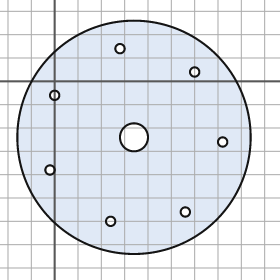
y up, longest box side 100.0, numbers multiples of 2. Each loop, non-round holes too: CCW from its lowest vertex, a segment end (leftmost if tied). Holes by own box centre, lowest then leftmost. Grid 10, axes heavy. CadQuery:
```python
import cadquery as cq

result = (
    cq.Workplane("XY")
    .moveTo(34.0, -24.0)
    .circle(50.0)
    .moveTo(24.0, -60.0)
    .circle(2.0)
    .moveTo(56.0, -56.0)
    .circle(2.0)
    .moveTo(-2.0, -38.0)
    .circle(2.0)
    .moveTo(72.0, -26.0)
    .circle(2.0)
    .moveTo(34.0, -24.0)
    .circle(6.0)
    .moveTo(0.0, -6.0)
    .circle(2.0)
    .moveTo(60.0, 4.0)
    .circle(2.0)
    .moveTo(28.0, 14.0)
    .circle(2.0)
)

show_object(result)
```